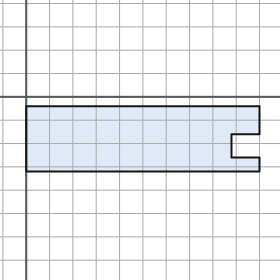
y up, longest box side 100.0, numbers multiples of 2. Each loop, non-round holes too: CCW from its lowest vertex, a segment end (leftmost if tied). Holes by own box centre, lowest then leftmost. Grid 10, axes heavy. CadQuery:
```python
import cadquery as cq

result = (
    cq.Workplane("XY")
    .moveTo(0.0, -32.0)
    .lineTo(100.0, -32.0)
    .lineTo(100.0, -26.0)
    .lineTo(88.0, -26.0)
    .lineTo(88.0, -16.0)
    .lineTo(100.0, -16.0)
    .lineTo(100.0, -4.0)
    .lineTo(0.0, -4.0)
    .close()
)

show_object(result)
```